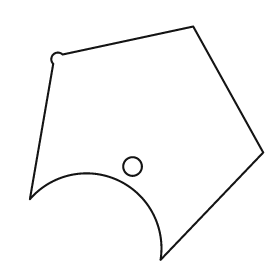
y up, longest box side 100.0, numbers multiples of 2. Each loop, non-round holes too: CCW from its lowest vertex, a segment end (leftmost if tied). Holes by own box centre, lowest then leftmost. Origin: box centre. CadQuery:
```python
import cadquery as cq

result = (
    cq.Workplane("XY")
    .moveTo(6.0, -50.0)
    .lineTo(50.0, -4.0)
    .lineTo(20.0, 50.0)
    .lineTo(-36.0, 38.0)
    .threePointArc((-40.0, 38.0), (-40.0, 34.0))
    .lineTo(-50.0, -24.0)
    .threePointArc((-12.0, -16.0), (6.0, -50.0))
    .close()
    .moveTo(-6.0, -10.0)
    .circle(4.0)
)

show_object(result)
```